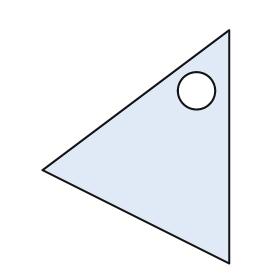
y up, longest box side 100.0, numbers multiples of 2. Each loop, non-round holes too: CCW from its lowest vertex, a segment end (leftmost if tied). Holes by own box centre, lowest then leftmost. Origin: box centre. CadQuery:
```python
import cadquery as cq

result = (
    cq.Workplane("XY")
    .moveTo(40.0, -50.0)
    .lineTo(40.0, 50.0)
    .lineTo(-40.0, -10.0)
    .close()
    .moveTo(26.0, 24.0)
    .circle(8.0)
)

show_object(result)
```